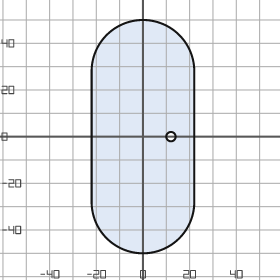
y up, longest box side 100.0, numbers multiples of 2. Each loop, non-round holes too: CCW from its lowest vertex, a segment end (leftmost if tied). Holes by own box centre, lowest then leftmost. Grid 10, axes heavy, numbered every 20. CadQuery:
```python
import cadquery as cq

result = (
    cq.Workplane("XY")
    .moveTo(-22.0, -28.0)
    .threePointArc((0.0, -50.0), (22.0, -28.0))
    .lineTo(22.0, 28.0)
    .threePointArc((0.0, 50.0), (-22.0, 28.0))
    .close()
    .moveTo(12.0, 0.0)
    .circle(2.0)
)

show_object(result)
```